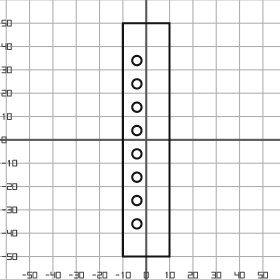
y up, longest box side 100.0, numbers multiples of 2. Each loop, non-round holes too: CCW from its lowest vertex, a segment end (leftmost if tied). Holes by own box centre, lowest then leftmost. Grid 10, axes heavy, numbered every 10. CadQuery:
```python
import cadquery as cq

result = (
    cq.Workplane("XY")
    .moveTo(-10.0, -50.0)
    .lineTo(10.0, -50.0)
    .lineTo(10.0, 50.0)
    .lineTo(-10.0, 50.0)
    .close()
    .moveTo(-4.0, -36.0)
    .circle(2.0)
    .moveTo(-4.0, -26.0)
    .circle(2.0)
    .moveTo(-4.0, -16.0)
    .circle(2.0)
    .moveTo(-4.0, -6.0)
    .circle(2.0)
    .moveTo(-4.0, 4.0)
    .circle(2.0)
    .moveTo(-4.0, 14.0)
    .circle(2.0)
    .moveTo(-4.0, 24.0)
    .circle(2.0)
    .moveTo(-4.0, 34.0)
    .circle(2.0)
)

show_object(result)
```